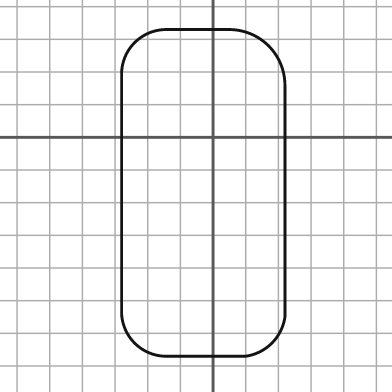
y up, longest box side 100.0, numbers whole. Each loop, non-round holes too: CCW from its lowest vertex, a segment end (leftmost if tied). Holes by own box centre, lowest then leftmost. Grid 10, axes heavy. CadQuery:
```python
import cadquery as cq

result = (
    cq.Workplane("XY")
    .moveTo(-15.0, -67.0)
    .lineTo(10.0, -67.0)
    .threePointArc((18.0, -63.0), (22.0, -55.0))
    .lineTo(22.0, 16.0)
    .threePointArc((17.0, 28.0), (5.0, 33.0))
    .lineTo(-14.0, 33.0)
    .threePointArc((-24.0, 29.0), (-28.0, 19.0))
    .lineTo(-28.0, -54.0)
    .threePointArc((-24.0, -63.0), (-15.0, -67.0))
    .close()
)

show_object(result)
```